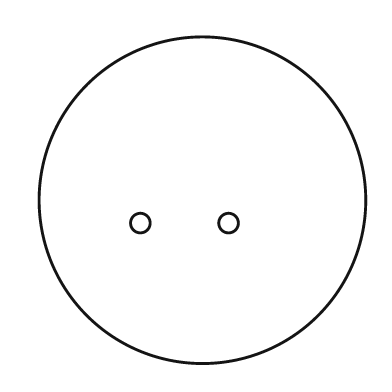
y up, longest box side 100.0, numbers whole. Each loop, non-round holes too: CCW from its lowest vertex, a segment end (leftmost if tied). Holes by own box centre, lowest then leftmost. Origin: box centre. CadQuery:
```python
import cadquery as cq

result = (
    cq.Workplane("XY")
    .moveTo(0.0, 0.0)
    .circle(50.0)
    .moveTo(-19.0, -7.0)
    .circle(3.0)
    .moveTo(8.0, -7.0)
    .circle(3.0)
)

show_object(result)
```